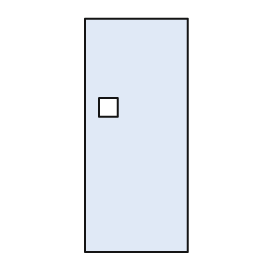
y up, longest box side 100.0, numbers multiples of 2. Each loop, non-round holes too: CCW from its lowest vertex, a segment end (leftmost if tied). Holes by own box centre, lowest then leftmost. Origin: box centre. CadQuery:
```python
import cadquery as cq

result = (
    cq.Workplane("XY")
    .moveTo(-22.0, -50.0)
    .lineTo(22.0, -50.0)
    .lineTo(22.0, 50.0)
    .lineTo(-22.0, 50.0)
    .close()
    .moveTo(-16.0, 8.0)
    .lineTo(-8.0, 8.0)
    .lineTo(-8.0, 16.0)
    .lineTo(-16.0, 16.0)
    .close()
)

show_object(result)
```